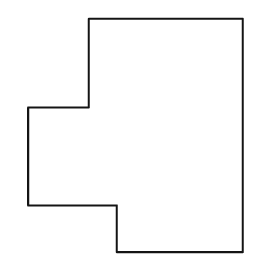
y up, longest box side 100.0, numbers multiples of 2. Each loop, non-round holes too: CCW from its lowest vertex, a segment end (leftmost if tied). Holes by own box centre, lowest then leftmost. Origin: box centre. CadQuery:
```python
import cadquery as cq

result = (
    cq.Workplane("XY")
    .moveTo(-8.0, -50.0)
    .lineTo(46.0, -50.0)
    .lineTo(46.0, 50.0)
    .lineTo(-20.0, 50.0)
    .lineTo(-20.0, 12.0)
    .lineTo(-46.0, 12.0)
    .lineTo(-46.0, -30.0)
    .lineTo(-8.0, -30.0)
    .close()
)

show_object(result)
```